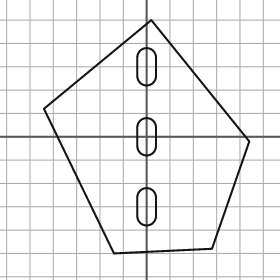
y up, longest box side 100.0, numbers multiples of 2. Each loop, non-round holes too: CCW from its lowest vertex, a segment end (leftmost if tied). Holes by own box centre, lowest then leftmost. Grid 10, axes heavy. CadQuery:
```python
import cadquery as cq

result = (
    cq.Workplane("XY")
    .moveTo(-14.0, -50.0)
    .lineTo(28.0, -48.0)
    .lineTo(44.0, -2.0)
    .lineTo(2.0, 50.0)
    .lineTo(-44.0, 12.0)
    .close()
    .moveTo(-4.0, -34.0)
    .threePointArc((0.0, -38.0), (4.0, -34.0))
    .lineTo(4.0, -26.0)
    .threePointArc((0.0, -22.0), (-4.0, -26.0))
    .close()
    .moveTo(-4.0, -4.0)
    .threePointArc((0.0, -8.0), (4.0, -4.0))
    .lineTo(4.0, 4.0)
    .threePointArc((0.0, 8.0), (-4.0, 4.0))
    .close()
    .moveTo(-4.0, 26.0)
    .threePointArc((0.0, 22.0), (4.0, 26.0))
    .lineTo(4.0, 34.0)
    .threePointArc((0.0, 38.0), (-4.0, 34.0))
    .close()
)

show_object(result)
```